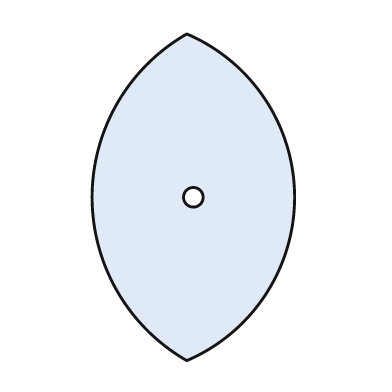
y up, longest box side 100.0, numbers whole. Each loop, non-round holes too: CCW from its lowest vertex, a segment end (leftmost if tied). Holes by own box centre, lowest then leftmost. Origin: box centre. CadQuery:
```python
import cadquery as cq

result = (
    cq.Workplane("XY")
    .moveTo(-2.0, -50.0)
    .threePointArc((31.0, 0.0), (-2.0, 50.0))
    .threePointArc((-31.0, 0.0), (-2.0, -50.0))
    .close()
    .moveTo(0.0, 0.0)
    .circle(3.0)
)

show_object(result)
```